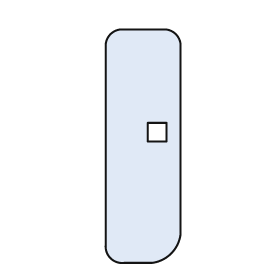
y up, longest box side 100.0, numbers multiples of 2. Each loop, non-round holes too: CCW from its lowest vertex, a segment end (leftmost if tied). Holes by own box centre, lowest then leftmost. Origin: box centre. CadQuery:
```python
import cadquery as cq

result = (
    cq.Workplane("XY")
    .moveTo(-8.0, -50.0)
    .lineTo(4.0, -50.0)
    .threePointArc((12.0, -46.0), (16.0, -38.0))
    .lineTo(16.0, 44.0)
    .threePointArc((14.0, 48.0), (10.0, 50.0))
    .lineTo(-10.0, 50.0)
    .threePointArc((-14.0, 48.0), (-16.0, 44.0))
    .lineTo(-16.0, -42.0)
    .threePointArc((-14.0, -48.0), (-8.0, -50.0))
    .close()
    .moveTo(2.0, 2.0)
    .lineTo(10.0, 2.0)
    .lineTo(10.0, 10.0)
    .lineTo(2.0, 10.0)
    .close()
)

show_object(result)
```